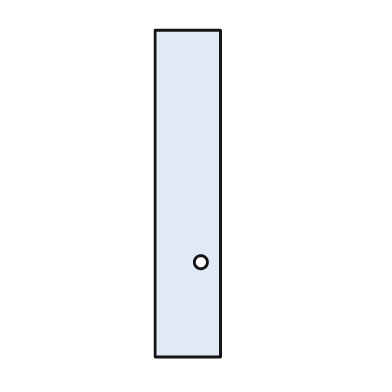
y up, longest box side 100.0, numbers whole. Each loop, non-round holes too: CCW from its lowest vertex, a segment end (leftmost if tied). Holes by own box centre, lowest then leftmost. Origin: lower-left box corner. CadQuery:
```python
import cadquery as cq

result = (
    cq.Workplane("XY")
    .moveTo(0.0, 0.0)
    .lineTo(20.0, 0.0)
    .lineTo(20.0, 100.0)
    .lineTo(0.0, 100.0)
    .close()
    .moveTo(14.0, 29.0)
    .circle(2.0)
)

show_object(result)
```